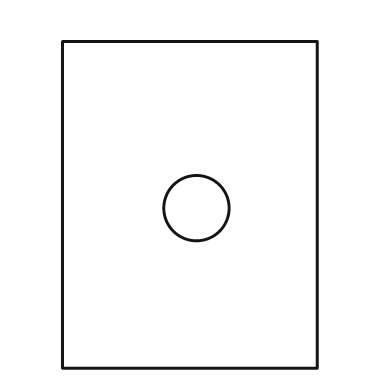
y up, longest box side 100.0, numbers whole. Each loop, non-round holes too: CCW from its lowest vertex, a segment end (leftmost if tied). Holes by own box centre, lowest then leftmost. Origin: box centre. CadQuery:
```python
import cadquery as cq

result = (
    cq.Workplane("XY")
    .moveTo(-39.0, -50.0)
    .lineTo(39.0, -50.0)
    .lineTo(39.0, 50.0)
    .lineTo(-39.0, 50.0)
    .close()
    .moveTo(2.0, -1.0)
    .circle(10.0)
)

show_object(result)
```